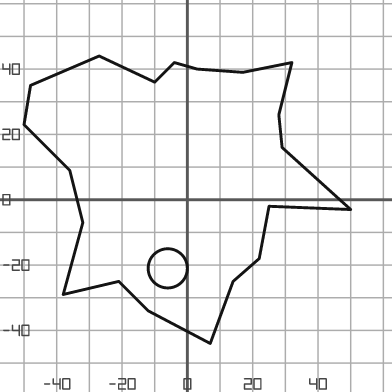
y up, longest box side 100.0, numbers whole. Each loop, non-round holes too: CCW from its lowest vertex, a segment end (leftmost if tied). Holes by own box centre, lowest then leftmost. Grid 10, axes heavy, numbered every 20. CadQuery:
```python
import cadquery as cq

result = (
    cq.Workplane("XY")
    .moveTo(7.0, -44.0)
    .lineTo(14.0, -25.0)
    .lineTo(22.0, -18.0)
    .lineTo(25.0, -2.0)
    .lineTo(50.0, -3.0)
    .lineTo(29.0, 16.0)
    .lineTo(28.0, 26.0)
    .lineTo(32.0, 42.0)
    .lineTo(17.0, 39.0)
    .lineTo(3.0, 40.0)
    .lineTo(-4.0, 42.0)
    .lineTo(-10.0, 36.0)
    .lineTo(-27.0, 44.0)
    .lineTo(-48.0, 35.0)
    .lineTo(-50.0, 23.0)
    .lineTo(-36.0, 9.0)
    .lineTo(-32.0, -7.0)
    .lineTo(-38.0, -29.0)
    .lineTo(-21.0, -25.0)
    .lineTo(-12.0, -34.0)
    .close()
    .moveTo(-6.0, -21.0)
    .circle(6.0)
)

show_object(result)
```